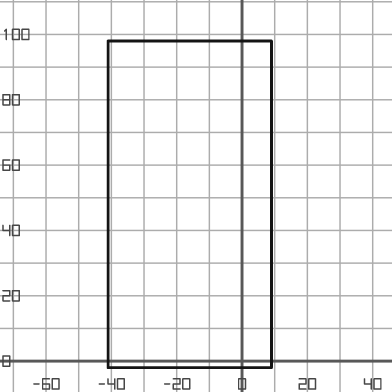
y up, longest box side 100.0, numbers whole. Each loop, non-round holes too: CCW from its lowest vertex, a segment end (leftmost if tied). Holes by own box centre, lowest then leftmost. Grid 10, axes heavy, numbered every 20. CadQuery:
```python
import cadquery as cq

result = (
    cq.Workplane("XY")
    .moveTo(-41.0, -2.0)
    .lineTo(9.0, -2.0)
    .lineTo(9.0, 98.0)
    .lineTo(-41.0, 98.0)
    .close()
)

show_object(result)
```